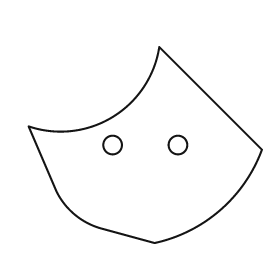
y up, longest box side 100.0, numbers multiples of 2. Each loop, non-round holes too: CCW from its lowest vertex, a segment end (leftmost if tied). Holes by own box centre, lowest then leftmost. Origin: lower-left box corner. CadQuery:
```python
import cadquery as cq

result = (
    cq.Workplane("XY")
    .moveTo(54.0, 0.0)
    .threePointArc((82.0, 14.0), (100.0, 40.0))
    .lineTo(56.0, 84.0)
    .threePointArc((36.0, 54.0), (0.0, 50.0))
    .lineTo(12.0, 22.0)
    .threePointArc((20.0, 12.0), (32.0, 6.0))
    .close()
    .moveTo(36.0, 42.0)
    .circle(4.0)
    .moveTo(64.0, 42.0)
    .circle(4.0)
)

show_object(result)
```